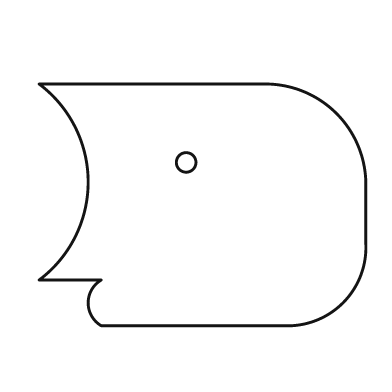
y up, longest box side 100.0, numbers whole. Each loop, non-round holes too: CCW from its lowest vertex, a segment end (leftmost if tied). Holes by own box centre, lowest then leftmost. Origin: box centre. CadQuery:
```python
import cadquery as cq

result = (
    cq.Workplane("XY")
    .moveTo(-31.0, -37.0)
    .lineTo(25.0, -37.0)
    .threePointArc((43.0, -30.0), (50.0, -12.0))
    .lineTo(50.0, 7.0)
    .threePointArc((41.0, 28.0), (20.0, 37.0))
    .lineTo(-50.0, 37.0)
    .threePointArc((-35.0, 7.0), (-50.0, -23.0))
    .lineTo(-31.0, -23.0)
    .threePointArc((-35.0, -30.0), (-31.0, -37.0))
    .close()
    .moveTo(-5.0, 13.0)
    .circle(3.0)
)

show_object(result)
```